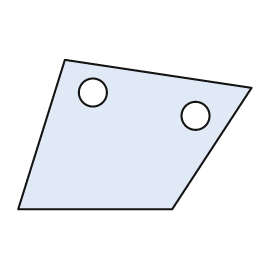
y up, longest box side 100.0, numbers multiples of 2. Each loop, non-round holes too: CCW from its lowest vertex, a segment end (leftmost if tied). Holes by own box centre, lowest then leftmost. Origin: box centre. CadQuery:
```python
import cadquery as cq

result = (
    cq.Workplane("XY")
    .moveTo(-50.0, -32.0)
    .lineTo(16.0, -32.0)
    .lineTo(50.0, 20.0)
    .lineTo(-30.0, 32.0)
    .close()
    .moveTo(26.0, 8.0)
    .circle(6.0)
    .moveTo(-18.0, 18.0)
    .circle(6.0)
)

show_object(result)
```